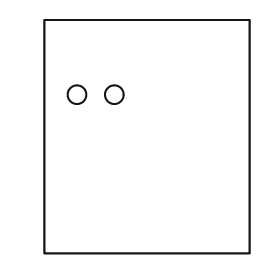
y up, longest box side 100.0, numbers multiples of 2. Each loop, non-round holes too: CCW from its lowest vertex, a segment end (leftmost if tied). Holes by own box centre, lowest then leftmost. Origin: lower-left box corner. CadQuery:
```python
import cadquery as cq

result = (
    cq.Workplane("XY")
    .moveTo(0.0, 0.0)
    .lineTo(88.0, 0.0)
    .lineTo(88.0, 100.0)
    .lineTo(0.0, 100.0)
    .close()
    .moveTo(14.0, 68.0)
    .circle(4.0)
    .moveTo(30.0, 68.0)
    .circle(4.0)
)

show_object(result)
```